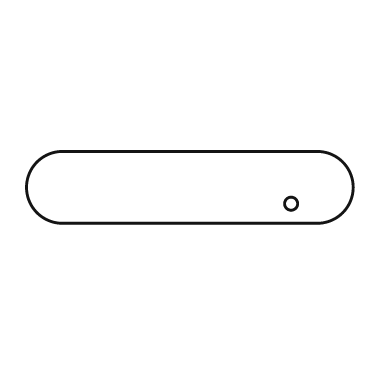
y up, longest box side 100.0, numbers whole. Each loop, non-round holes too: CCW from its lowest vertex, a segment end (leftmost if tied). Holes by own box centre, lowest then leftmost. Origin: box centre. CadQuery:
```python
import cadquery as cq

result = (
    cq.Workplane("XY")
    .moveTo(-39.0, -11.0)
    .lineTo(39.0, -11.0)
    .threePointArc((50.0, 0.0), (39.0, 11.0))
    .lineTo(-39.0, 11.0)
    .threePointArc((-50.0, 0.0), (-39.0, -11.0))
    .close()
    .moveTo(31.0, -5.0)
    .circle(2.0)
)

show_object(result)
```